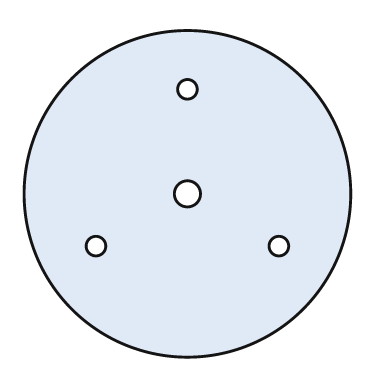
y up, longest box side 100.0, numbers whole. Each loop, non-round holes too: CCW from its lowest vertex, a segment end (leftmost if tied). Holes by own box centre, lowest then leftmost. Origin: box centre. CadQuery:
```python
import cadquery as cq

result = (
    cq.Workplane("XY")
    .moveTo(0.0, 0.0)
    .circle(50.0)
    .moveTo(-28.0, -16.0)
    .circle(3.0)
    .moveTo(28.0, -16.0)
    .circle(3.0)
    .moveTo(0.0, 0.0)
    .circle(4.0)
    .moveTo(0.0, 32.0)
    .circle(3.0)
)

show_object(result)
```